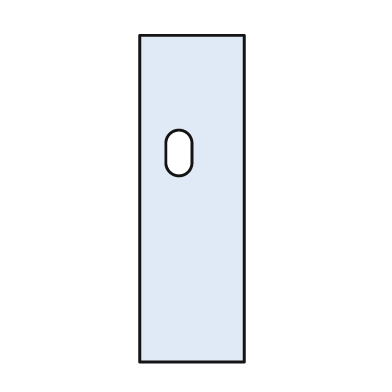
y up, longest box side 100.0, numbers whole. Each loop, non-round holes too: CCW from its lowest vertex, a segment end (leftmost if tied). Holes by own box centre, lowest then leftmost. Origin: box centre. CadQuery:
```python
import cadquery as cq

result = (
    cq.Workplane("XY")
    .moveTo(-16.0, -50.0)
    .lineTo(16.0, -50.0)
    .lineTo(16.0, 50.0)
    .lineTo(-16.0, 50.0)
    .close()
    .moveTo(-8.0, 11.0)
    .threePointArc((-4.0, 7.0), (0.0, 11.0))
    .lineTo(0.0, 17.0)
    .threePointArc((-4.0, 21.0), (-8.0, 17.0))
    .close()
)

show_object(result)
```